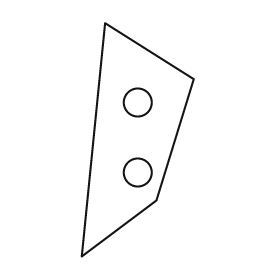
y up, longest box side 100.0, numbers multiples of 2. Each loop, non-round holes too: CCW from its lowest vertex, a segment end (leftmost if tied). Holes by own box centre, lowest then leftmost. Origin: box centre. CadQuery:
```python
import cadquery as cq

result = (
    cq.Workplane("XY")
    .moveTo(-24.0, -50.0)
    .lineTo(8.0, -26.0)
    .lineTo(24.0, 26.0)
    .lineTo(-14.0, 50.0)
    .close()
    .moveTo(0.0, -14.0)
    .circle(6.0)
    .moveTo(0.0, 16.0)
    .circle(6.0)
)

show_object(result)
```